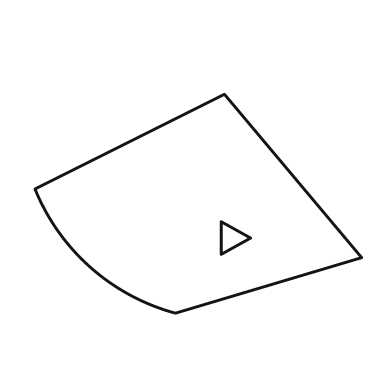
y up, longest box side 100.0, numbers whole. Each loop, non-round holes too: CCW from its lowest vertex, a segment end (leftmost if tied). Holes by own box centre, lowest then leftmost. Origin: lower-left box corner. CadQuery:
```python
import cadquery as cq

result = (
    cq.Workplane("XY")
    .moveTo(43.0, 0.0)
    .lineTo(100.0, 17.0)
    .lineTo(58.0, 67.0)
    .lineTo(0.0, 38.0)
    .threePointArc((17.0, 14.0), (43.0, 0.0))
    .close()
    .moveTo(57.0, 18.0)
    .lineTo(66.0, 23.0)
    .lineTo(57.0, 28.0)
    .close()
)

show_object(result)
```